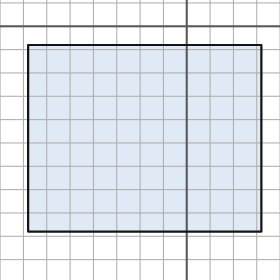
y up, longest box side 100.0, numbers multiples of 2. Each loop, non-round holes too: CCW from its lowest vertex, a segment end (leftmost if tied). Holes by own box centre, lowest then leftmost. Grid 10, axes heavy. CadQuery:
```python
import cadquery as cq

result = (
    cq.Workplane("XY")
    .moveTo(-68.0, -88.0)
    .lineTo(32.0, -88.0)
    .lineTo(32.0, -8.0)
    .lineTo(-68.0, -8.0)
    .close()
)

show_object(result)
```